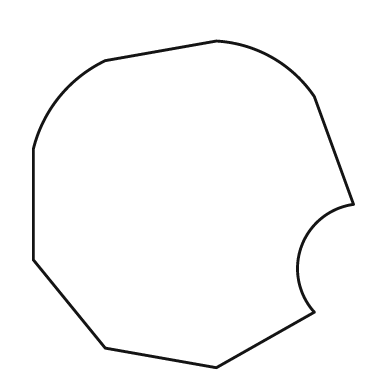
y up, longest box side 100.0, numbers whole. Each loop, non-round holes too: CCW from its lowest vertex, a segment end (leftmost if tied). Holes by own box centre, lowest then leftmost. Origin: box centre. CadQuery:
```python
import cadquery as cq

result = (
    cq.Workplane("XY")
    .moveTo(7.0, -50.0)
    .lineTo(37.0, -33.0)
    .threePointArc((33.0, -13.0), (49.0, 0.0))
    .lineTo(37.0, 33.0)
    .threePointArc((24.0, 45.0), (7.0, 50.0))
    .lineTo(-27.0, 44.0)
    .threePointArc((-41.0, 33.0), (-49.0, 17.0))
    .lineTo(-49.0, -17.0)
    .lineTo(-27.0, -44.0)
    .close()
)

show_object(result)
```